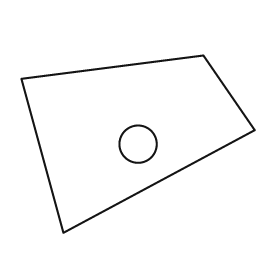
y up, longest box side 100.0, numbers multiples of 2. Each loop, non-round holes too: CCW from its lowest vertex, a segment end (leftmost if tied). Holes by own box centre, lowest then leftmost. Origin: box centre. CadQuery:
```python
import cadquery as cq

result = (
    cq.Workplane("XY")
    .moveTo(-32.0, -38.0)
    .lineTo(50.0, 6.0)
    .lineTo(28.0, 38.0)
    .lineTo(-50.0, 28.0)
    .close()
    .moveTo(0.0, 0.0)
    .circle(8.0)
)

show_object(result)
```